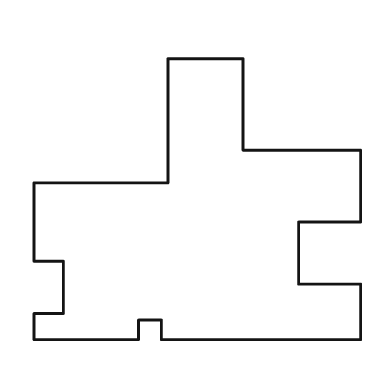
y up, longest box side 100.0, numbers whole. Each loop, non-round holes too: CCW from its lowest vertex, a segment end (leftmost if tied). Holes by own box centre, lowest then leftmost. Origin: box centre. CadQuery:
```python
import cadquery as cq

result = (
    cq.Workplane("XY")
    .moveTo(-50.0, -43.0)
    .lineTo(-18.0, -43.0)
    .lineTo(-18.0, -37.0)
    .lineTo(-11.0, -37.0)
    .lineTo(-11.0, -43.0)
    .lineTo(50.0, -43.0)
    .lineTo(50.0, -26.0)
    .lineTo(31.0, -26.0)
    .lineTo(31.0, -7.0)
    .lineTo(50.0, -7.0)
    .lineTo(50.0, 15.0)
    .lineTo(14.0, 15.0)
    .lineTo(14.0, 43.0)
    .lineTo(-9.0, 43.0)
    .lineTo(-9.0, 5.0)
    .lineTo(-50.0, 5.0)
    .lineTo(-50.0, -19.0)
    .lineTo(-41.0, -19.0)
    .lineTo(-41.0, -35.0)
    .lineTo(-50.0, -35.0)
    .close()
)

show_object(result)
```